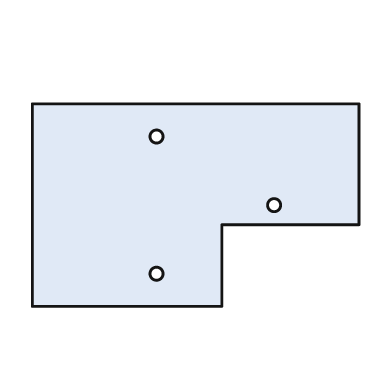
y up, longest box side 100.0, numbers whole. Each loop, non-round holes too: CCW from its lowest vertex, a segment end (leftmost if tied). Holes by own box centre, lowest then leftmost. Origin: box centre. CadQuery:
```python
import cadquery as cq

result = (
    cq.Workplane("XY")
    .moveTo(-50.0, -31.0)
    .lineTo(8.0, -31.0)
    .lineTo(8.0, -6.0)
    .lineTo(50.0, -6.0)
    .lineTo(50.0, 31.0)
    .lineTo(-50.0, 31.0)
    .close()
    .moveTo(-12.0, -21.0)
    .circle(2.0)
    .moveTo(24.0, 0.0)
    .circle(2.0)
    .moveTo(-12.0, 21.0)
    .circle(2.0)
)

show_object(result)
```